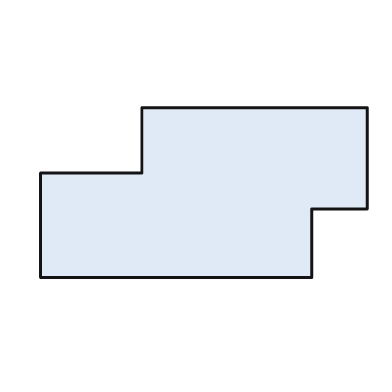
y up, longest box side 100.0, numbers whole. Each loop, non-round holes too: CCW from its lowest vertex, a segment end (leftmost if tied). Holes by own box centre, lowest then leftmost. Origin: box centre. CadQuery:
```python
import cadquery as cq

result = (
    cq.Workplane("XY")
    .moveTo(-50.0, -26.0)
    .lineTo(33.0, -26.0)
    .lineTo(33.0, -5.0)
    .lineTo(50.0, -5.0)
    .lineTo(50.0, 26.0)
    .lineTo(-19.0, 26.0)
    .lineTo(-19.0, 6.0)
    .lineTo(-50.0, 6.0)
    .close()
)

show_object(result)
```